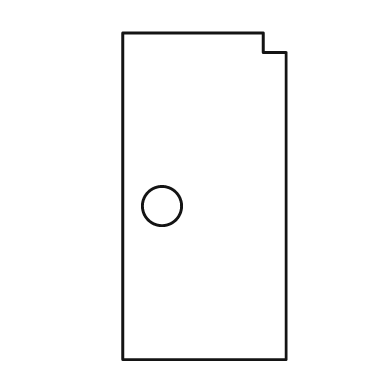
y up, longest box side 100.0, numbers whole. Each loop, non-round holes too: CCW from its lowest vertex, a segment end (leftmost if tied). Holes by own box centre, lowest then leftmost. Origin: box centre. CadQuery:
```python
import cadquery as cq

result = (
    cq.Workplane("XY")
    .moveTo(-25.0, -50.0)
    .lineTo(25.0, -50.0)
    .lineTo(25.0, 44.0)
    .lineTo(18.0, 44.0)
    .lineTo(18.0, 50.0)
    .lineTo(-25.0, 50.0)
    .close()
    .moveTo(-13.0, -3.0)
    .circle(6.0)
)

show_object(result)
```